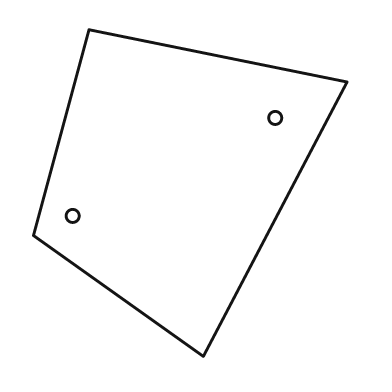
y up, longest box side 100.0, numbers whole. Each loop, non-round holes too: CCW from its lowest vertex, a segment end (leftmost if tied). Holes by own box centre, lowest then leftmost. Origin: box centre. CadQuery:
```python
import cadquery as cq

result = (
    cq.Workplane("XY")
    .moveTo(4.0, -50.0)
    .lineTo(48.0, 34.0)
    .lineTo(-31.0, 50.0)
    .lineTo(-48.0, -13.0)
    .close()
    .moveTo(-36.0, -7.0)
    .circle(2.0)
    .moveTo(26.0, 23.0)
    .circle(2.0)
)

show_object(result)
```